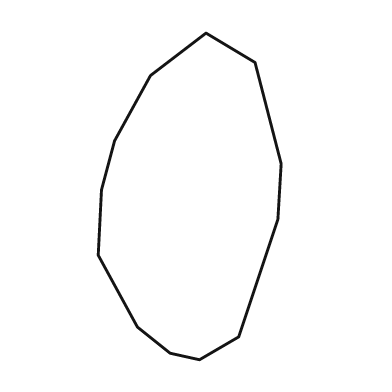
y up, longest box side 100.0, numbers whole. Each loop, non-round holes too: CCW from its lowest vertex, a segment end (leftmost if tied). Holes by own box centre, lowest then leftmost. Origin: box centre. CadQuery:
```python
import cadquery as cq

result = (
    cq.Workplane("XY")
    .moveTo(3.0, -50.0)
    .lineTo(15.0, -43.0)
    .lineTo(27.0, -7.0)
    .lineTo(28.0, 10.0)
    .lineTo(20.0, 41.0)
    .lineTo(5.0, 50.0)
    .lineTo(-12.0, 37.0)
    .lineTo(-23.0, 17.0)
    .lineTo(-27.0, 2.0)
    .lineTo(-28.0, -18.0)
    .lineTo(-16.0, -40.0)
    .lineTo(-6.0, -48.0)
    .close()
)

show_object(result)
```